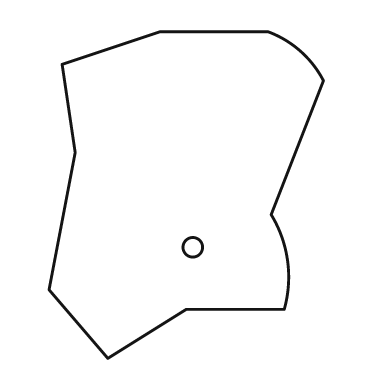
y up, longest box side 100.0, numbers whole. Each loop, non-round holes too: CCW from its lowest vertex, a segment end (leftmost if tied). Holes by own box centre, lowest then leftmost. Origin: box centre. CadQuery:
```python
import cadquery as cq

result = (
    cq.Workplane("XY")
    .moveTo(-24.0, -50.0)
    .lineTo(0.0, -35.0)
    .lineTo(30.0, -35.0)
    .threePointArc((31.0, -20.0), (26.0, -6.0))
    .lineTo(42.0, 35.0)
    .threePointArc((35.0, 44.0), (25.0, 50.0))
    .lineTo(-8.0, 50.0)
    .lineTo(-38.0, 40.0)
    .lineTo(-34.0, 13.0)
    .lineTo(-42.0, -29.0)
    .close()
    .moveTo(2.0, -16.0)
    .circle(3.0)
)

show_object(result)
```